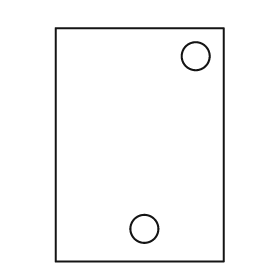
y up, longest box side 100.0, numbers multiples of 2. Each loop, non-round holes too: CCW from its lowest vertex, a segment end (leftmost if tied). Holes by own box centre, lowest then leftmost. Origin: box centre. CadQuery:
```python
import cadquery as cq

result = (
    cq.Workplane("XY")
    .moveTo(-36.0, -50.0)
    .lineTo(36.0, -50.0)
    .lineTo(36.0, 50.0)
    .lineTo(-36.0, 50.0)
    .close()
    .moveTo(2.0, -36.0)
    .circle(6.0)
    .moveTo(24.0, 38.0)
    .circle(6.0)
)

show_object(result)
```